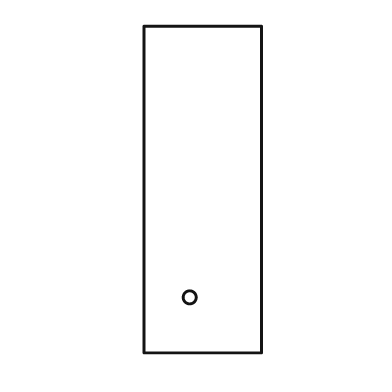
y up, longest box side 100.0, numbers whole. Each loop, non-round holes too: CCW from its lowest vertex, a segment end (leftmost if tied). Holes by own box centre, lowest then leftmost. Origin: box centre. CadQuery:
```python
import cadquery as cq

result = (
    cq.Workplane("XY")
    .moveTo(-18.0, -50.0)
    .lineTo(18.0, -50.0)
    .lineTo(18.0, 50.0)
    .lineTo(-18.0, 50.0)
    .close()
    .moveTo(-4.0, -33.0)
    .circle(2.0)
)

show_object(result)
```